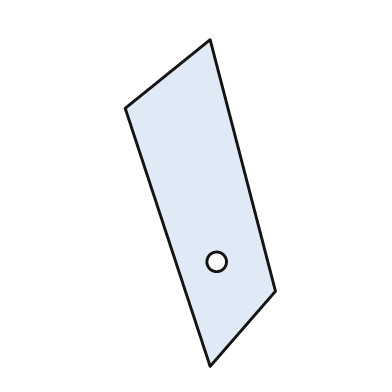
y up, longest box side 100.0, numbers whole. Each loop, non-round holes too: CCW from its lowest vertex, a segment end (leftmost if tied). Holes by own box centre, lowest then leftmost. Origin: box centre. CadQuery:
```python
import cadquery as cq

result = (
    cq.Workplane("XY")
    .moveTo(3.0, -50.0)
    .lineTo(23.0, -27.0)
    .lineTo(3.0, 50.0)
    .lineTo(-23.0, 29.0)
    .close()
    .moveTo(5.0, -18.0)
    .circle(3.0)
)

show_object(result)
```